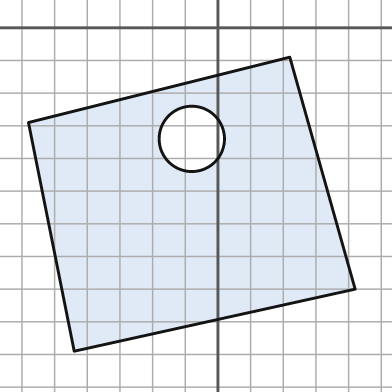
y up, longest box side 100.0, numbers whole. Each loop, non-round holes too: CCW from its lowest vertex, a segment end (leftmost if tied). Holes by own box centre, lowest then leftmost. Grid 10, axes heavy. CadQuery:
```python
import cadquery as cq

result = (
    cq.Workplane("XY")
    .moveTo(-44.0, -99.0)
    .lineTo(42.0, -80.0)
    .lineTo(22.0, -9.0)
    .lineTo(-58.0, -29.0)
    .close()
    .moveTo(-8.0, -34.0)
    .circle(10.0)
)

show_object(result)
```